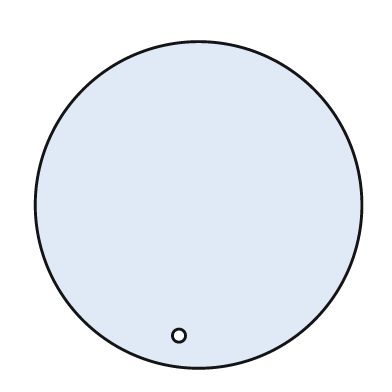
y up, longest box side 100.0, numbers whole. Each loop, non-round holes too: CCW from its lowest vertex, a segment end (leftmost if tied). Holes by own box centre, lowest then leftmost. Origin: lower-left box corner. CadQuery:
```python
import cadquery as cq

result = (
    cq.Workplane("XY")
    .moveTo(50.0, 50.0)
    .circle(50.0)
    .moveTo(44.0, 10.0)
    .circle(2.0)
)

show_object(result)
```